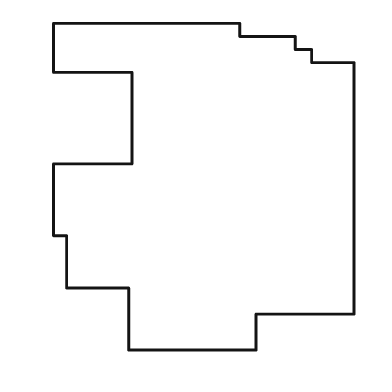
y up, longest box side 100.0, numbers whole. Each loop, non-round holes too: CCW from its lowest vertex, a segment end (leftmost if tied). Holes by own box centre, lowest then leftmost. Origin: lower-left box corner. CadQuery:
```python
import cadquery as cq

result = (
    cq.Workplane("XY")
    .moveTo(23.0, 0.0)
    .lineTo(62.0, 0.0)
    .lineTo(62.0, 11.0)
    .lineTo(92.0, 11.0)
    .lineTo(92.0, 88.0)
    .lineTo(79.0, 88.0)
    .lineTo(79.0, 92.0)
    .lineTo(74.0, 92.0)
    .lineTo(74.0, 96.0)
    .lineTo(57.0, 96.0)
    .lineTo(57.0, 100.0)
    .lineTo(0.0, 100.0)
    .lineTo(0.0, 85.0)
    .lineTo(24.0, 85.0)
    .lineTo(24.0, 57.0)
    .lineTo(0.0, 57.0)
    .lineTo(0.0, 35.0)
    .lineTo(4.0, 35.0)
    .lineTo(4.0, 19.0)
    .lineTo(23.0, 19.0)
    .close()
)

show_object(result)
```